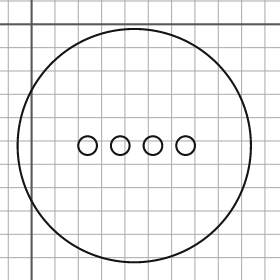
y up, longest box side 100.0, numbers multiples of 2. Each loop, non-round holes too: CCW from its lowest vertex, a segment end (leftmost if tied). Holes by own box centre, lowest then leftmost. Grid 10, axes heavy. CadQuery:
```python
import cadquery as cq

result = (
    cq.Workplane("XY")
    .moveTo(44.0, -52.0)
    .circle(50.0)
    .moveTo(24.0, -52.0)
    .circle(4.0)
    .moveTo(38.0, -52.0)
    .circle(4.0)
    .moveTo(52.0, -52.0)
    .circle(4.0)
    .moveTo(66.0, -52.0)
    .circle(4.0)
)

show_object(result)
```